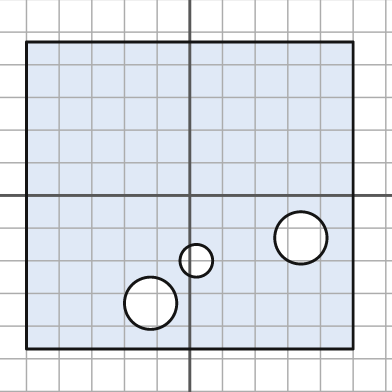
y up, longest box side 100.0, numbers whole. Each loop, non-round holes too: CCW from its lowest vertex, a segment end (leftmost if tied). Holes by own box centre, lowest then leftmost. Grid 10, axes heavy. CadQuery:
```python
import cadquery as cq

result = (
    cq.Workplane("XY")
    .moveTo(-50.0, -47.0)
    .lineTo(50.0, -47.0)
    .lineTo(50.0, 47.0)
    .lineTo(-50.0, 47.0)
    .close()
    .moveTo(-12.0, -33.0)
    .circle(8.0)
    .moveTo(2.0, -20.0)
    .circle(5.0)
    .moveTo(34.0, -13.0)
    .circle(8.0)
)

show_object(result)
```